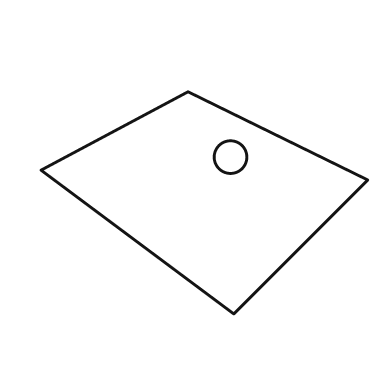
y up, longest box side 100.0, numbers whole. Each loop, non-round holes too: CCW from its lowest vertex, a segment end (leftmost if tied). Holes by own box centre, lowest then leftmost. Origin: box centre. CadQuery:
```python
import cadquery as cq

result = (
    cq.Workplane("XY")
    .moveTo(9.0, -34.0)
    .lineTo(50.0, 7.0)
    .lineTo(-5.0, 34.0)
    .lineTo(-50.0, 10.0)
    .close()
    .moveTo(8.0, 14.0)
    .circle(5.0)
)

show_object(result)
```